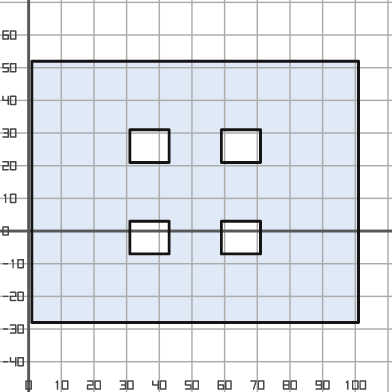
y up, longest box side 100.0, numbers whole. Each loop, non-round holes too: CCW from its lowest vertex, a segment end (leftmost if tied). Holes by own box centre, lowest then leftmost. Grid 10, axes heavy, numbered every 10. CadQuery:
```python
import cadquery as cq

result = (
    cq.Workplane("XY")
    .moveTo(1.0, -28.0)
    .lineTo(101.0, -28.0)
    .lineTo(101.0, 52.0)
    .lineTo(1.0, 52.0)
    .close()
    .moveTo(31.0, -7.0)
    .lineTo(43.0, -7.0)
    .lineTo(43.0, 3.0)
    .lineTo(31.0, 3.0)
    .close()
    .moveTo(59.0, -7.0)
    .lineTo(71.0, -7.0)
    .lineTo(71.0, 3.0)
    .lineTo(59.0, 3.0)
    .close()
    .moveTo(31.0, 21.0)
    .lineTo(43.0, 21.0)
    .lineTo(43.0, 31.0)
    .lineTo(31.0, 31.0)
    .close()
    .moveTo(59.0, 21.0)
    .lineTo(71.0, 21.0)
    .lineTo(71.0, 31.0)
    .lineTo(59.0, 31.0)
    .close()
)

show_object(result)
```